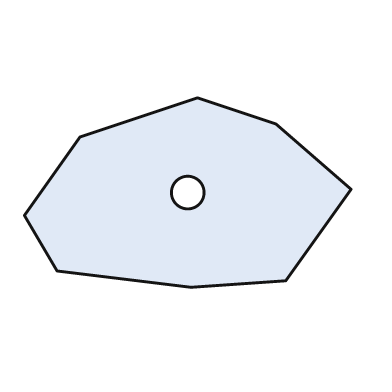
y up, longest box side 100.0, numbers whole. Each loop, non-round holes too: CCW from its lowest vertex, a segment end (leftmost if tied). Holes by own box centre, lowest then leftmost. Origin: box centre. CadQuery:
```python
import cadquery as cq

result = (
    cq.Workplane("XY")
    .moveTo(1.0, -29.0)
    .lineTo(30.0, -27.0)
    .lineTo(50.0, 1.0)
    .lineTo(27.0, 21.0)
    .lineTo(3.0, 29.0)
    .lineTo(-33.0, 17.0)
    .lineTo(-50.0, -7.0)
    .lineTo(-40.0, -24.0)
    .close()
    .moveTo(0.0, 0.0)
    .circle(5.0)
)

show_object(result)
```